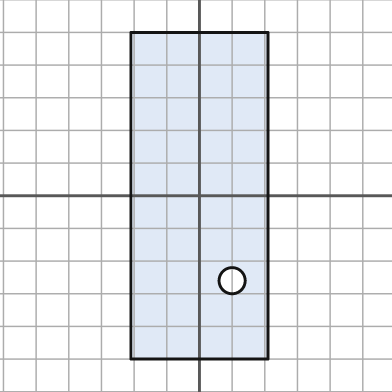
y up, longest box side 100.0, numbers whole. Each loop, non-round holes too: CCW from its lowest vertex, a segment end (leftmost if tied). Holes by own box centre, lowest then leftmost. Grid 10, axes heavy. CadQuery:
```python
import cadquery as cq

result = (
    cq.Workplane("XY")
    .moveTo(-21.0, -50.0)
    .lineTo(21.0, -50.0)
    .lineTo(21.0, 50.0)
    .lineTo(-21.0, 50.0)
    .close()
    .moveTo(10.0, -26.0)
    .circle(4.0)
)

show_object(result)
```